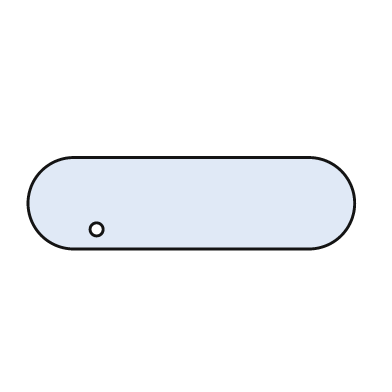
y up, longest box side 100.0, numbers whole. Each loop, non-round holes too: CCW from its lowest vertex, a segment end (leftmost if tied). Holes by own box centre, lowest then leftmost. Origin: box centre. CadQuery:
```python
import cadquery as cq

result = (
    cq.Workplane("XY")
    .moveTo(-36.0, -14.0)
    .lineTo(36.0, -14.0)
    .threePointArc((50.0, 0.0), (36.0, 14.0))
    .lineTo(-36.0, 14.0)
    .threePointArc((-50.0, 0.0), (-36.0, -14.0))
    .close()
    .moveTo(-29.0, -8.0)
    .circle(2.0)
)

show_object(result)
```